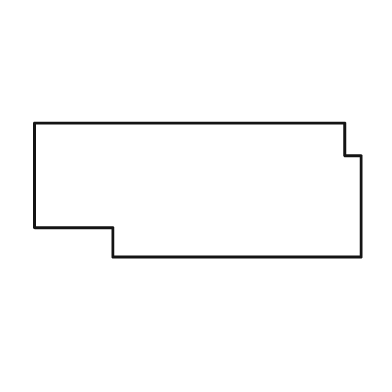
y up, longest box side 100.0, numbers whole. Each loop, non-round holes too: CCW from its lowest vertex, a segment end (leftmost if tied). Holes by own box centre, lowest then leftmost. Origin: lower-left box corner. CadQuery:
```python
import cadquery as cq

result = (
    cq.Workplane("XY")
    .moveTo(24.0, 0.0)
    .lineTo(100.0, 0.0)
    .lineTo(100.0, 31.0)
    .lineTo(95.0, 31.0)
    .lineTo(95.0, 41.0)
    .lineTo(0.0, 41.0)
    .lineTo(0.0, 9.0)
    .lineTo(24.0, 9.0)
    .close()
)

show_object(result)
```